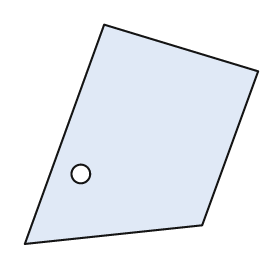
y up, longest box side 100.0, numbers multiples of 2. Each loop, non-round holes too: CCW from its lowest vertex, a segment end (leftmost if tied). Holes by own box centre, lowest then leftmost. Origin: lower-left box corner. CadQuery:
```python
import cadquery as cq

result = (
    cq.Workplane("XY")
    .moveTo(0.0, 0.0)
    .lineTo(76.0, 8.0)
    .lineTo(100.0, 74.0)
    .lineTo(34.0, 94.0)
    .close()
    .moveTo(24.0, 30.0)
    .circle(4.0)
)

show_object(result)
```